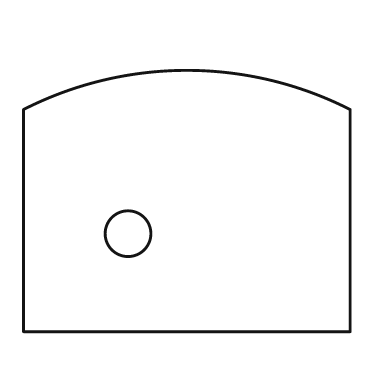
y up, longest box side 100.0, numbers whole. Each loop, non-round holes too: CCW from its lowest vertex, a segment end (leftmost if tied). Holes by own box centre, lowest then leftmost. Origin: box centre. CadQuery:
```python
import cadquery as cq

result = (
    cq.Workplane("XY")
    .moveTo(-50.0, -40.0)
    .lineTo(50.0, -40.0)
    .lineTo(50.0, 28.0)
    .threePointArc((0.0, 40.0), (-50.0, 28.0))
    .close()
    .moveTo(-18.0, -10.0)
    .circle(7.0)
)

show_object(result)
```